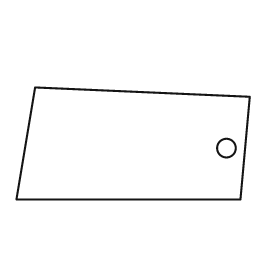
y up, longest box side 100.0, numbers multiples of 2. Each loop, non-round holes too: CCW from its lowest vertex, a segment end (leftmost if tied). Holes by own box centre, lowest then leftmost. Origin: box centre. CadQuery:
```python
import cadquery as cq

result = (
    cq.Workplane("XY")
    .moveTo(-50.0, -24.0)
    .lineTo(46.0, -24.0)
    .lineTo(50.0, 20.0)
    .lineTo(-42.0, 24.0)
    .close()
    .moveTo(40.0, -2.0)
    .circle(4.0)
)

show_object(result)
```